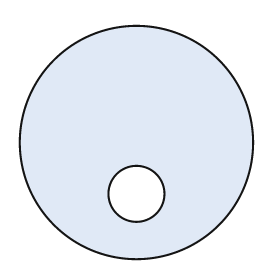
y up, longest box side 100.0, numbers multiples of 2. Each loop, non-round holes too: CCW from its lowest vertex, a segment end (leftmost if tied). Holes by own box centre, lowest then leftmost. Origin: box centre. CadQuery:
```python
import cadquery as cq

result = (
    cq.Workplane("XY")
    .moveTo(0.0, 0.0)
    .circle(50.0)
    .moveTo(0.0, -22.0)
    .circle(12.0)
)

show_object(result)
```